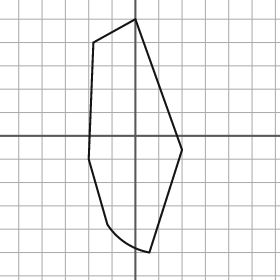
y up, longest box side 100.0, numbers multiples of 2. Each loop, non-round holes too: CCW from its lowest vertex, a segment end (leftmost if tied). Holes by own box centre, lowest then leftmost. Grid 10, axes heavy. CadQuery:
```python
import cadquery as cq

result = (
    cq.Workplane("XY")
    .moveTo(6.0, -50.0)
    .lineTo(20.0, -6.0)
    .lineTo(0.0, 50.0)
    .lineTo(-18.0, 40.0)
    .lineTo(-20.0, -10.0)
    .lineTo(-12.0, -38.0)
    .threePointArc((-4.0, -46.0), (6.0, -50.0))
    .close()
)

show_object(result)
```